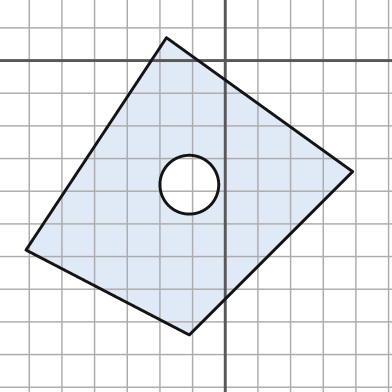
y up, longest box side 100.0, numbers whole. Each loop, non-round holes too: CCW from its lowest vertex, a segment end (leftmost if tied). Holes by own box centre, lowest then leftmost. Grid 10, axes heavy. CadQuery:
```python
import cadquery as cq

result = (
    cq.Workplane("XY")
    .moveTo(-11.0, -84.0)
    .lineTo(39.0, -34.0)
    .lineTo(-18.0, 7.0)
    .lineTo(-61.0, -58.0)
    .close()
    .moveTo(-11.0, -38.0)
    .circle(9.0)
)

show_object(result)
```